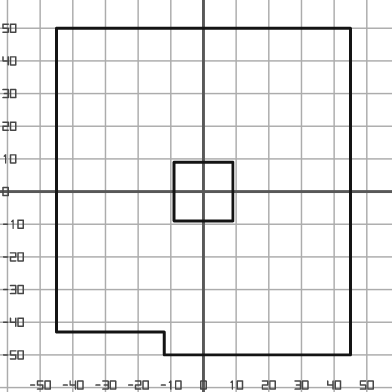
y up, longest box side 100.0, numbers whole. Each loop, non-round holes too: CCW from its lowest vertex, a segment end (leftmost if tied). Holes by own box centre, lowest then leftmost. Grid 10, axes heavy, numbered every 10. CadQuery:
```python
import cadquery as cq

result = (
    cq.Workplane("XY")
    .moveTo(-12.0, -50.0)
    .lineTo(45.0, -50.0)
    .lineTo(45.0, 50.0)
    .lineTo(-45.0, 50.0)
    .lineTo(-45.0, -43.0)
    .lineTo(-12.0, -43.0)
    .close()
    .moveTo(-9.0, -9.0)
    .lineTo(9.0, -9.0)
    .lineTo(9.0, 9.0)
    .lineTo(-9.0, 9.0)
    .close()
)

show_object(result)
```